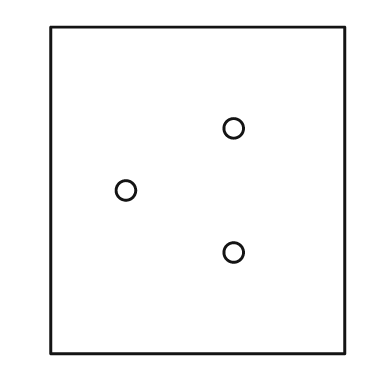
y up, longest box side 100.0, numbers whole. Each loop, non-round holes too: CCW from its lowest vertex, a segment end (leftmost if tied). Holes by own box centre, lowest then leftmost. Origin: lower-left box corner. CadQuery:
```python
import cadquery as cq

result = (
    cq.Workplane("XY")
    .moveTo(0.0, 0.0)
    .lineTo(90.0, 0.0)
    .lineTo(90.0, 100.0)
    .lineTo(0.0, 100.0)
    .close()
    .moveTo(56.0, 31.0)
    .circle(3.0)
    .moveTo(23.0, 50.0)
    .circle(3.0)
    .moveTo(56.0, 69.0)
    .circle(3.0)
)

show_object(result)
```